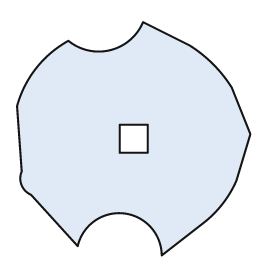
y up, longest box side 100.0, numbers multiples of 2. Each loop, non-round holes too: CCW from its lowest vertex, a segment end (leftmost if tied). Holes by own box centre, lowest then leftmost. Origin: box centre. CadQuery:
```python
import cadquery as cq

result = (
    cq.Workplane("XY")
    .moveTo(12.0, -50.0)
    .lineTo(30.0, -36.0)
    .threePointArc((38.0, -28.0), (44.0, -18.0))
    .lineTo(50.0, 2.0)
    .lineTo(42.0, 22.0)
    .threePointArc((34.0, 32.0), (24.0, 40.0))
    .lineTo(4.0, 50.0)
    .threePointArc((-10.0, 38.0), (-28.0, 42.0))
    .threePointArc((-42.0, 30.0), (-50.0, 14.0))
    .lineTo(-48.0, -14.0)
    .threePointArc((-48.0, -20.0), (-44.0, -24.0))
    .lineTo(-24.0, -46.0)
    .threePointArc((-4.0, -32.0), (12.0, -50.0))
    .close()
    .moveTo(-6.0, -6.0)
    .lineTo(6.0, -6.0)
    .lineTo(6.0, 6.0)
    .lineTo(-6.0, 6.0)
    .close()
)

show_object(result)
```